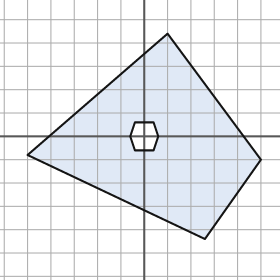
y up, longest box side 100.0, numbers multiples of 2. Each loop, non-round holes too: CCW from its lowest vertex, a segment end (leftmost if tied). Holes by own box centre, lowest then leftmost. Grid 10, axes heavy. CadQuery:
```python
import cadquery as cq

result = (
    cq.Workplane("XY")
    .moveTo(26.0, -44.0)
    .lineTo(50.0, -10.0)
    .lineTo(10.0, 44.0)
    .lineTo(-50.0, -8.0)
    .close()
    .moveTo(-4.0, -6.0)
    .lineTo(4.0, -6.0)
    .lineTo(6.0, 0.0)
    .lineTo(4.0, 6.0)
    .lineTo(-4.0, 6.0)
    .lineTo(-6.0, 0.0)
    .close()
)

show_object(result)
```